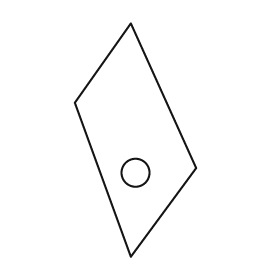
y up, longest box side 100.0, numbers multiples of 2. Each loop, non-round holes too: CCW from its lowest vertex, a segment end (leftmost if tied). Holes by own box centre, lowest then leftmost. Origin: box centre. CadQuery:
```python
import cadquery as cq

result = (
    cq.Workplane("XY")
    .moveTo(-2.0, -50.0)
    .lineTo(26.0, -12.0)
    .lineTo(-2.0, 50.0)
    .lineTo(-26.0, 16.0)
    .close()
    .moveTo(0.0, -14.0)
    .circle(6.0)
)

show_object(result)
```